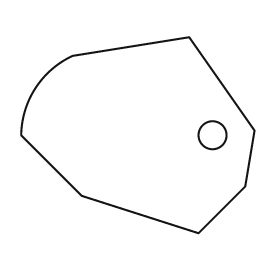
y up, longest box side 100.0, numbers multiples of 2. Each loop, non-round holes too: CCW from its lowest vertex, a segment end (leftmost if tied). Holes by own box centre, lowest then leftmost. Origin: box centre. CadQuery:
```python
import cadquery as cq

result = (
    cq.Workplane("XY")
    .moveTo(26.0, -42.0)
    .lineTo(46.0, -22.0)
    .lineTo(50.0, 2.0)
    .lineTo(22.0, 42.0)
    .lineTo(-28.0, 34.0)
    .threePointArc((-44.0, 20.0), (-50.0, 0.0))
    .lineTo(-24.0, -26.0)
    .close()
    .moveTo(32.0, 0.0)
    .circle(6.0)
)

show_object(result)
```